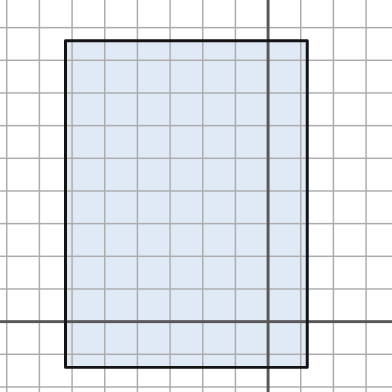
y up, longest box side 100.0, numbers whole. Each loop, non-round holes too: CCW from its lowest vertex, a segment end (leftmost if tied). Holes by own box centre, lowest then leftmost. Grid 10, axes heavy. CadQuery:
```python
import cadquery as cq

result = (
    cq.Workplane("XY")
    .moveTo(-62.0, -14.0)
    .lineTo(12.0, -14.0)
    .lineTo(12.0, 86.0)
    .lineTo(-62.0, 86.0)
    .close()
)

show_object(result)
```